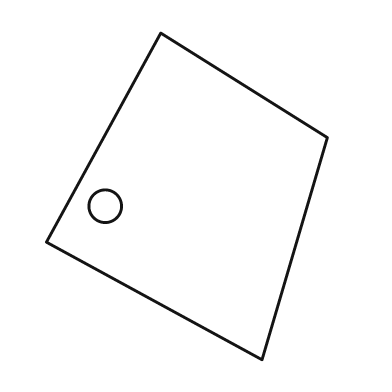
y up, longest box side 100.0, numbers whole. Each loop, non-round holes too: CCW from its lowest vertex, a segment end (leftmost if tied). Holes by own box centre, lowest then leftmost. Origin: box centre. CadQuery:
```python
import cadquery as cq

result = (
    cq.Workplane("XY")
    .moveTo(23.0, -50.0)
    .lineTo(43.0, 18.0)
    .lineTo(-8.0, 50.0)
    .lineTo(-43.0, -14.0)
    .close()
    .moveTo(-25.0, -3.0)
    .circle(5.0)
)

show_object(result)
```